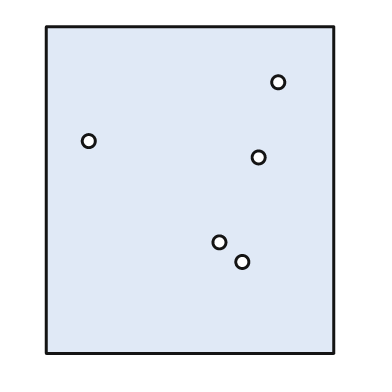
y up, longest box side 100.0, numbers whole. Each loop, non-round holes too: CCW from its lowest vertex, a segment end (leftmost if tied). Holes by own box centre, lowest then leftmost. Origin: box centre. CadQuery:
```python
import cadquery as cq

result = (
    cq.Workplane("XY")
    .moveTo(-44.0, -50.0)
    .lineTo(44.0, -50.0)
    .lineTo(44.0, 50.0)
    .lineTo(-44.0, 50.0)
    .close()
    .moveTo(16.0, -22.0)
    .circle(2.0)
    .moveTo(9.0, -16.0)
    .circle(2.0)
    .moveTo(21.0, 10.0)
    .circle(2.0)
    .moveTo(-31.0, 15.0)
    .circle(2.0)
    .moveTo(27.0, 33.0)
    .circle(2.0)
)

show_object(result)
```